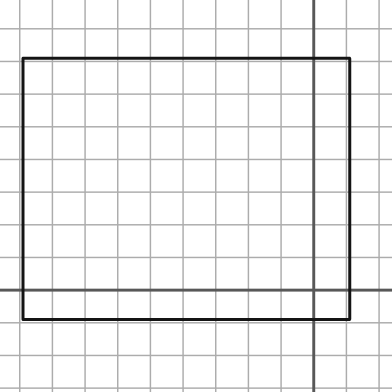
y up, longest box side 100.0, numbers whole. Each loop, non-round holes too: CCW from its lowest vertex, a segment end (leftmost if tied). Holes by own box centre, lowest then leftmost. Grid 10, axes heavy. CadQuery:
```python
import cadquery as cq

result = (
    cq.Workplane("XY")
    .moveTo(-89.0, -9.0)
    .lineTo(11.0, -9.0)
    .lineTo(11.0, 71.0)
    .lineTo(-89.0, 71.0)
    .close()
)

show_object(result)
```